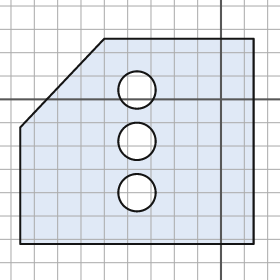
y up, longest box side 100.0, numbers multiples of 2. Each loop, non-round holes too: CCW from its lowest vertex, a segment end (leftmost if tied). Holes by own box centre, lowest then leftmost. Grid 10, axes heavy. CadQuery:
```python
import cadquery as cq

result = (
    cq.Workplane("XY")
    .moveTo(-86.0, -62.0)
    .lineTo(14.0, -62.0)
    .lineTo(14.0, 26.0)
    .lineTo(-50.0, 26.0)
    .lineTo(-86.0, -12.0)
    .close()
    .moveTo(-36.0, -40.0)
    .circle(8.0)
    .moveTo(-36.0, -18.0)
    .circle(8.0)
    .moveTo(-36.0, 4.0)
    .circle(8.0)
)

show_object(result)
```